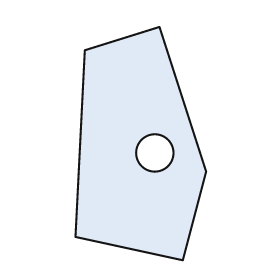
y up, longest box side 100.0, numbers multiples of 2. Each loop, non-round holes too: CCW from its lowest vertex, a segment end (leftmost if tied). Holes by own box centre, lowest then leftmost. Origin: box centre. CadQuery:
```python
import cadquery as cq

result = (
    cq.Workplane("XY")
    .moveTo(18.0, -50.0)
    .lineTo(28.0, -12.0)
    .lineTo(8.0, 50.0)
    .lineTo(-24.0, 40.0)
    .lineTo(-28.0, -40.0)
    .close()
    .moveTo(6.0, -4.0)
    .circle(8.0)
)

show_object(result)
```